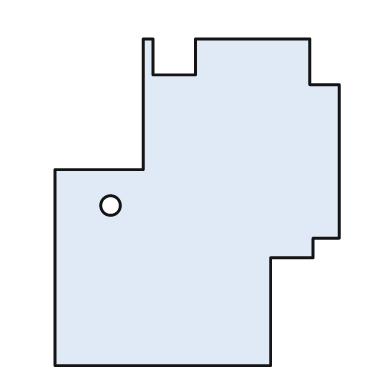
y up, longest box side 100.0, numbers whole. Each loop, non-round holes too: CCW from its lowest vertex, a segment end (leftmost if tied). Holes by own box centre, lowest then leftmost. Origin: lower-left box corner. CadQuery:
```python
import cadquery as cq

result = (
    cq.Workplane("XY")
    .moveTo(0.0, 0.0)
    .lineTo(66.0, 0.0)
    .lineTo(66.0, 33.0)
    .lineTo(79.0, 33.0)
    .lineTo(79.0, 39.0)
    .lineTo(87.0, 39.0)
    .lineTo(87.0, 86.0)
    .lineTo(78.0, 86.0)
    .lineTo(78.0, 100.0)
    .lineTo(43.0, 100.0)
    .lineTo(43.0, 89.0)
    .lineTo(30.0, 89.0)
    .lineTo(30.0, 100.0)
    .lineTo(27.0, 100.0)
    .lineTo(27.0, 60.0)
    .lineTo(0.0, 60.0)
    .close()
    .moveTo(17.0, 49.0)
    .circle(3.0)
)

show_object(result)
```